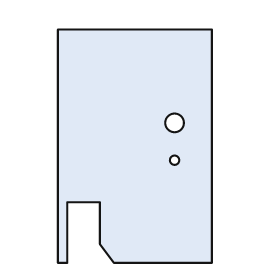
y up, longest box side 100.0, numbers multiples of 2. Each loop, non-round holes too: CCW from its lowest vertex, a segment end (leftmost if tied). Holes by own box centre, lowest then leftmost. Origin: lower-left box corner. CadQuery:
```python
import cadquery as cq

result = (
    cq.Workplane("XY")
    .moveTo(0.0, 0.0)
    .lineTo(4.0, 0.0)
    .lineTo(4.0, 26.0)
    .lineTo(18.0, 26.0)
    .lineTo(18.0, 8.0)
    .lineTo(24.0, 0.0)
    .lineTo(66.0, 0.0)
    .lineTo(66.0, 100.0)
    .lineTo(0.0, 100.0)
    .close()
    .moveTo(50.0, 44.0)
    .circle(2.0)
    .moveTo(50.0, 60.0)
    .circle(4.0)
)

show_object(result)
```